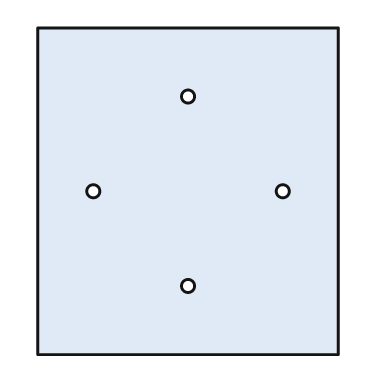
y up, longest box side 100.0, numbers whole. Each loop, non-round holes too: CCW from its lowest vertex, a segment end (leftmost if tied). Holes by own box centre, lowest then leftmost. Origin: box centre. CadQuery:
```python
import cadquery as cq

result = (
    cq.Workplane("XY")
    .moveTo(-46.0, -50.0)
    .lineTo(46.0, -50.0)
    .lineTo(46.0, 50.0)
    .lineTo(-46.0, 50.0)
    .close()
    .moveTo(0.0, -29.0)
    .circle(2.0)
    .moveTo(-29.0, 0.0)
    .circle(2.0)
    .moveTo(29.0, 0.0)
    .circle(2.0)
    .moveTo(0.0, 29.0)
    .circle(2.0)
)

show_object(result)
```